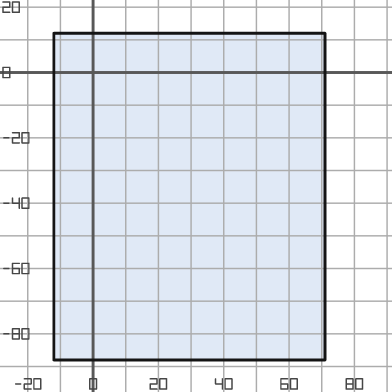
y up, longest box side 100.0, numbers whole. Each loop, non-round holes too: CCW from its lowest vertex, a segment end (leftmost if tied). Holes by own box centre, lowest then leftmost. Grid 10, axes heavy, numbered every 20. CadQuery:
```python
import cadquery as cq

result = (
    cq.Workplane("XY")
    .moveTo(-12.0, -88.0)
    .lineTo(71.0, -88.0)
    .lineTo(71.0, 12.0)
    .lineTo(-12.0, 12.0)
    .close()
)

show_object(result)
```